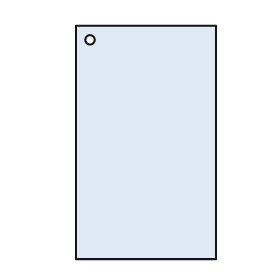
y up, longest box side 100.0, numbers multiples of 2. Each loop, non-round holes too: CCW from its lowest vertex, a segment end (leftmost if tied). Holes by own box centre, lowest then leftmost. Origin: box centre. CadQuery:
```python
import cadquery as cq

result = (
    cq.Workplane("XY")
    .moveTo(-30.0, -50.0)
    .lineTo(30.0, -50.0)
    .lineTo(30.0, 50.0)
    .lineTo(-30.0, 50.0)
    .close()
    .moveTo(-24.0, 44.0)
    .circle(2.0)
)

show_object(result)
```